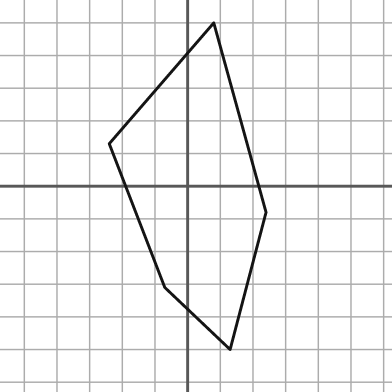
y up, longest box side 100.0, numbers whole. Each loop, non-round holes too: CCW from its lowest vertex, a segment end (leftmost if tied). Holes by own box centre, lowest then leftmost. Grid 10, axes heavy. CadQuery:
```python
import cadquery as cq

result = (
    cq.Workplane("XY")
    .moveTo(13.0, -50.0)
    .lineTo(24.0, -8.0)
    .lineTo(8.0, 50.0)
    .lineTo(-24.0, 13.0)
    .lineTo(-7.0, -31.0)
    .close()
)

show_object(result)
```